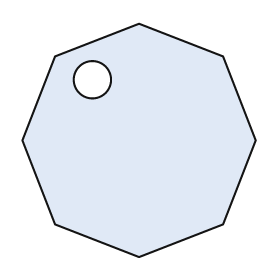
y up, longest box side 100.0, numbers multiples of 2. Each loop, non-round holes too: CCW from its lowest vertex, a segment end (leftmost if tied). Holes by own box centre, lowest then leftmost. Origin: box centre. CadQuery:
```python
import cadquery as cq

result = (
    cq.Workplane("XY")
    .moveTo(0.0, -50.0)
    .lineTo(36.0, -36.0)
    .lineTo(50.0, 0.0)
    .lineTo(36.0, 36.0)
    .lineTo(0.0, 50.0)
    .lineTo(-36.0, 36.0)
    .lineTo(-50.0, 0.0)
    .lineTo(-36.0, -36.0)
    .close()
    .moveTo(-20.0, 26.0)
    .circle(8.0)
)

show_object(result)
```